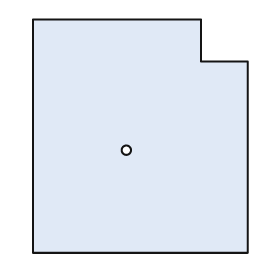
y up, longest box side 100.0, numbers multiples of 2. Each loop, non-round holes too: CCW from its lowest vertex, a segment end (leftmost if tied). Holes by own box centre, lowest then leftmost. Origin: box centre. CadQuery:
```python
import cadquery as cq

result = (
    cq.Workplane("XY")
    .moveTo(-46.0, -50.0)
    .lineTo(46.0, -50.0)
    .lineTo(46.0, 32.0)
    .lineTo(26.0, 32.0)
    .lineTo(26.0, 50.0)
    .lineTo(-46.0, 50.0)
    .close()
    .moveTo(-6.0, -6.0)
    .circle(2.0)
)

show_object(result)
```